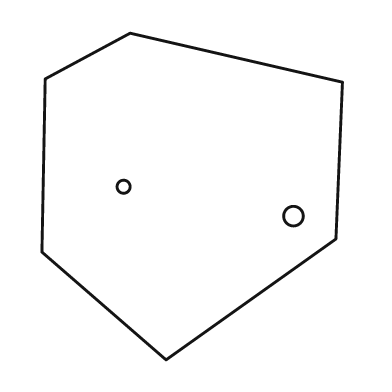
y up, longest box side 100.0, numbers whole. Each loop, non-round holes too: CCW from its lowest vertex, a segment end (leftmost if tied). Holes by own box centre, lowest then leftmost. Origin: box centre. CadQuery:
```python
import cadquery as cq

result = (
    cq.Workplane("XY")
    .moveTo(-8.0, -50.0)
    .lineTo(44.0, -13.0)
    .lineTo(46.0, 35.0)
    .lineTo(-19.0, 50.0)
    .lineTo(-45.0, 36.0)
    .lineTo(-46.0, -17.0)
    .close()
    .moveTo(31.0, -6.0)
    .circle(3.0)
    .moveTo(-21.0, 3.0)
    .circle(2.0)
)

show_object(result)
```